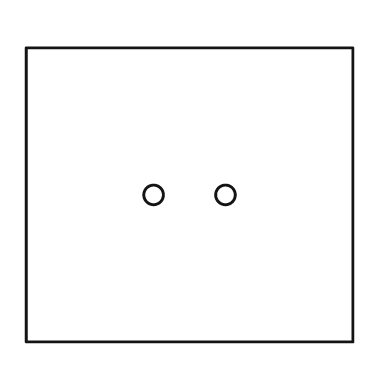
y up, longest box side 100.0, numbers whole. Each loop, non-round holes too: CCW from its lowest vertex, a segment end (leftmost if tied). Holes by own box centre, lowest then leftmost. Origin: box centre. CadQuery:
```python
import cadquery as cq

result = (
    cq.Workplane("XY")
    .moveTo(-50.0, -45.0)
    .lineTo(50.0, -45.0)
    .lineTo(50.0, 45.0)
    .lineTo(-50.0, 45.0)
    .close()
    .moveTo(-11.0, 0.0)
    .circle(3.0)
    .moveTo(11.0, 0.0)
    .circle(3.0)
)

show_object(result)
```